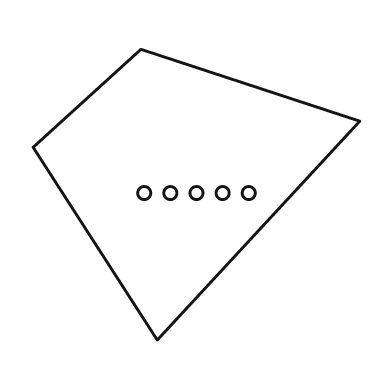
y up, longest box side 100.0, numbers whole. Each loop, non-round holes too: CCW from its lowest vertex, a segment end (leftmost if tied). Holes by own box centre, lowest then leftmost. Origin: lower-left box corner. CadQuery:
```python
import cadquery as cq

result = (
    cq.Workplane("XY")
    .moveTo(38.0, 0.0)
    .lineTo(100.0, 67.0)
    .lineTo(33.0, 89.0)
    .lineTo(0.0, 59.0)
    .close()
    .moveTo(34.0, 45.0)
    .circle(2.0)
    .moveTo(42.0, 45.0)
    .circle(2.0)
    .moveTo(50.0, 45.0)
    .circle(2.0)
    .moveTo(58.0, 45.0)
    .circle(2.0)
    .moveTo(66.0, 45.0)
    .circle(2.0)
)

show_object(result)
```